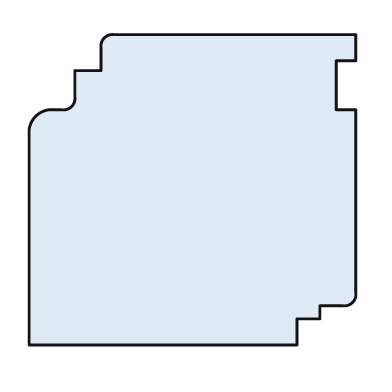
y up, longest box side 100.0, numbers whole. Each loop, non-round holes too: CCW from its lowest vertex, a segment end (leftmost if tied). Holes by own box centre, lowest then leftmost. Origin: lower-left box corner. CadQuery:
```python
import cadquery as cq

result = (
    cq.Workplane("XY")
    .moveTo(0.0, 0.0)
    .lineTo(82.0, 0.0)
    .lineTo(82.0, 8.0)
    .lineTo(89.0, 8.0)
    .lineTo(89.0, 12.0)
    .lineTo(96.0, 12.0)
    .threePointArc((99.0, 13.0), (100.0, 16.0))
    .lineTo(100.0, 72.0)
    .lineTo(94.0, 72.0)
    .lineTo(94.0, 87.0)
    .lineTo(100.0, 87.0)
    .lineTo(100.0, 95.0)
    .lineTo(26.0, 95.0)
    .threePointArc((23.0, 94.0), (22.0, 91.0))
    .lineTo(22.0, 84.0)
    .lineTo(14.0, 84.0)
    .lineTo(14.0, 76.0)
    .threePointArc((13.0, 73.0), (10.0, 72.0))
    .lineTo(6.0, 72.0)
    .threePointArc((2.0, 70.0), (0.0, 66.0))
    .close()
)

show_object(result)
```